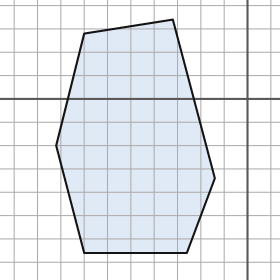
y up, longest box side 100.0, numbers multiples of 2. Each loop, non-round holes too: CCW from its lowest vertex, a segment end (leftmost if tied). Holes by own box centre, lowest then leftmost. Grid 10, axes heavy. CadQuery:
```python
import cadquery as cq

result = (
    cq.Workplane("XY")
    .moveTo(-70.0, -66.0)
    .lineTo(-26.0, -66.0)
    .lineTo(-14.0, -34.0)
    .lineTo(-32.0, 34.0)
    .lineTo(-70.0, 28.0)
    .lineTo(-82.0, -20.0)
    .close()
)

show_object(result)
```